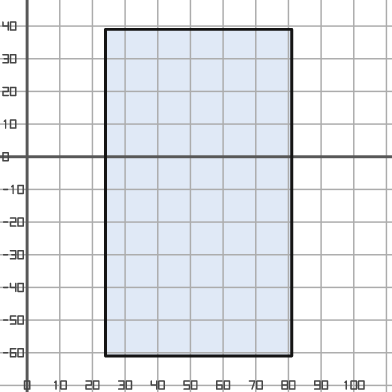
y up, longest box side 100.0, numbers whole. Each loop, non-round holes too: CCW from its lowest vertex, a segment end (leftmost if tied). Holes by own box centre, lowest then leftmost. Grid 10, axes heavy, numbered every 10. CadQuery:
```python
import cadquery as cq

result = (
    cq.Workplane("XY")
    .moveTo(24.0, -61.0)
    .lineTo(81.0, -61.0)
    .lineTo(81.0, 39.0)
    .lineTo(24.0, 39.0)
    .close()
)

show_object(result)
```